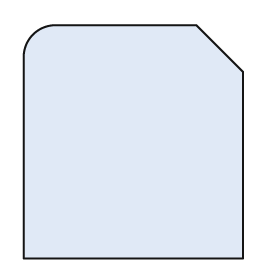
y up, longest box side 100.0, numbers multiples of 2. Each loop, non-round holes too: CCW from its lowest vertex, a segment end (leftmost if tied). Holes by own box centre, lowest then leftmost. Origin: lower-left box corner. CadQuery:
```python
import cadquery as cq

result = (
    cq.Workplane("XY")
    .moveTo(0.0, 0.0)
    .lineTo(94.0, 0.0)
    .lineTo(94.0, 80.0)
    .lineTo(74.0, 100.0)
    .lineTo(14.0, 100.0)
    .threePointArc((4.0, 96.0), (0.0, 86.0))
    .close()
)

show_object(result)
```